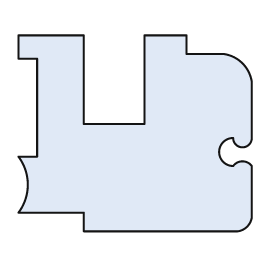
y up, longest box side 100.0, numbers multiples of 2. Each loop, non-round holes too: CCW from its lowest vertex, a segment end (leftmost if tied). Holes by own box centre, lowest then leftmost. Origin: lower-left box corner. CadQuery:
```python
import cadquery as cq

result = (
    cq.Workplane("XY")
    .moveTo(28.0, 0.0)
    .lineTo(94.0, 0.0)
    .threePointArc((98.0, 2.0), (100.0, 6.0))
    .lineTo(100.0, 28.0)
    .threePointArc((96.0, 30.0), (92.0, 28.0))
    .threePointArc((86.0, 34.0), (92.0, 40.0))
    .threePointArc((96.0, 36.0), (100.0, 40.0))
    .lineTo(100.0, 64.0)
    .threePointArc((96.0, 72.0), (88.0, 76.0))
    .lineTo(72.0, 76.0)
    .lineTo(72.0, 84.0)
    .lineTo(54.0, 84.0)
    .lineTo(54.0, 46.0)
    .lineTo(28.0, 46.0)
    .lineTo(28.0, 84.0)
    .lineTo(0.0, 84.0)
    .lineTo(0.0, 74.0)
    .lineTo(8.0, 74.0)
    .lineTo(8.0, 32.0)
    .lineTo(0.0, 32.0)
    .threePointArc((4.0, 20.0), (0.0, 8.0))
    .lineTo(28.0, 8.0)
    .close()
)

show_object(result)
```